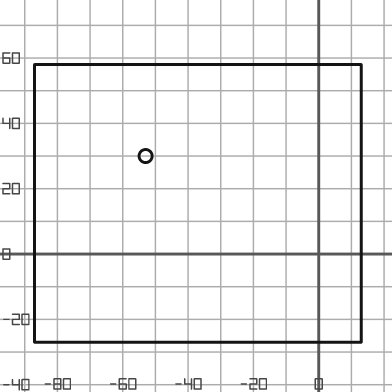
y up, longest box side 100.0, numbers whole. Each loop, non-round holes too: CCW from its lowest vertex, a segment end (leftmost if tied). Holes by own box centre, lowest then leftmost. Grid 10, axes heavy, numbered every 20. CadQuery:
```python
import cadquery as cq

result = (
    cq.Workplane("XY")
    .moveTo(-87.0, -27.0)
    .lineTo(13.0, -27.0)
    .lineTo(13.0, 58.0)
    .lineTo(-87.0, 58.0)
    .close()
    .moveTo(-53.0, 30.0)
    .circle(2.0)
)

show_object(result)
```